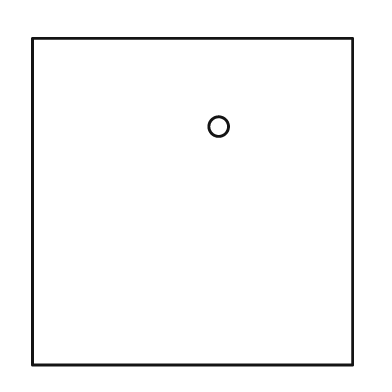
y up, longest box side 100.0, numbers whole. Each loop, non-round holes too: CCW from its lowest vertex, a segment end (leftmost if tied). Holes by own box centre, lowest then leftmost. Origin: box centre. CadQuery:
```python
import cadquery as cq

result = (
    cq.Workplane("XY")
    .moveTo(-49.0, -50.0)
    .lineTo(49.0, -50.0)
    .lineTo(49.0, 50.0)
    .lineTo(-49.0, 50.0)
    .close()
    .moveTo(8.0, 23.0)
    .circle(3.0)
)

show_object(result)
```